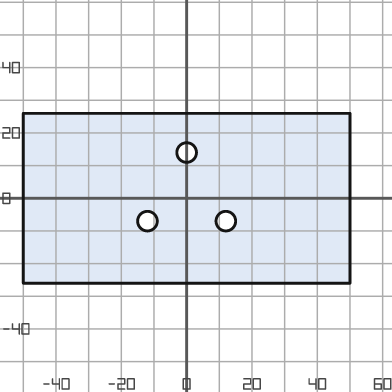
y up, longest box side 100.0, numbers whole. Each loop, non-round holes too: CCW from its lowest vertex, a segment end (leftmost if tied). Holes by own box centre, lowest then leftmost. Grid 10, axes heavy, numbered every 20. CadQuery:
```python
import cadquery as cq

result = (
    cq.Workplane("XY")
    .moveTo(-50.0, -26.0)
    .lineTo(50.0, -26.0)
    .lineTo(50.0, 26.0)
    .lineTo(-50.0, 26.0)
    .close()
    .moveTo(-12.0, -7.0)
    .circle(3.0)
    .moveTo(12.0, -7.0)
    .circle(3.0)
    .moveTo(0.0, 14.0)
    .circle(3.0)
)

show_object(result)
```